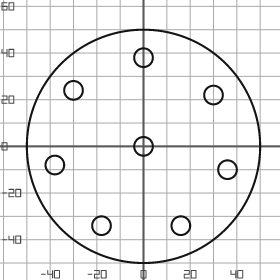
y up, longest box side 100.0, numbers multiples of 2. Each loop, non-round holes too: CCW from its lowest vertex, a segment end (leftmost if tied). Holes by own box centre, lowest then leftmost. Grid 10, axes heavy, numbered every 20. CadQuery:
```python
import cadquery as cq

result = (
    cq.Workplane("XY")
    .moveTo(0.0, 0.0)
    .circle(50.0)
    .moveTo(-18.0, -34.0)
    .circle(4.0)
    .moveTo(16.0, -34.0)
    .circle(4.0)
    .moveTo(36.0, -10.0)
    .circle(4.0)
    .moveTo(-38.0, -8.0)
    .circle(4.0)
    .moveTo(0.0, 0.0)
    .circle(4.0)
    .moveTo(30.0, 22.0)
    .circle(4.0)
    .moveTo(-30.0, 24.0)
    .circle(4.0)
    .moveTo(0.0, 38.0)
    .circle(4.0)
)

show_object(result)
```